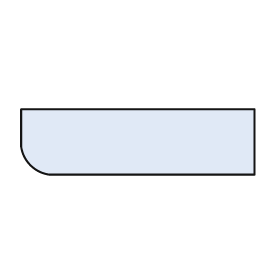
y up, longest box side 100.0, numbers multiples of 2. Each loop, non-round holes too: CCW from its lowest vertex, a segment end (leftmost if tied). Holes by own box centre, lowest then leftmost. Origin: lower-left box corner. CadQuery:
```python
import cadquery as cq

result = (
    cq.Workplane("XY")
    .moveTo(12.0, 0.0)
    .lineTo(100.0, 0.0)
    .lineTo(100.0, 28.0)
    .lineTo(0.0, 28.0)
    .lineTo(0.0, 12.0)
    .threePointArc((4.0, 4.0), (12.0, 0.0))
    .close()
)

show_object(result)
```